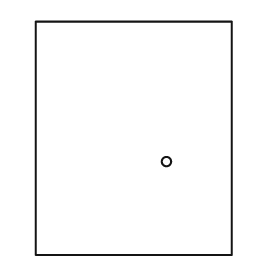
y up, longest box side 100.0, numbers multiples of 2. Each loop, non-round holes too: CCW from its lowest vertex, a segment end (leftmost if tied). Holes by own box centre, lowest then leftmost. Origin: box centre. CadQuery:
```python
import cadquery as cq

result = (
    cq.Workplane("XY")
    .moveTo(-42.0, -50.0)
    .lineTo(42.0, -50.0)
    .lineTo(42.0, 50.0)
    .lineTo(-42.0, 50.0)
    .close()
    .moveTo(14.0, -10.0)
    .circle(2.0)
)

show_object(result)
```